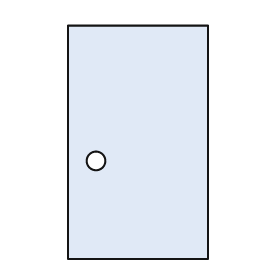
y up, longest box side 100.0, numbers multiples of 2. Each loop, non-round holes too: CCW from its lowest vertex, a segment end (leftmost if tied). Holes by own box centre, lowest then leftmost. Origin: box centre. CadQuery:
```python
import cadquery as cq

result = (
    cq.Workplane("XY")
    .moveTo(-30.0, -50.0)
    .lineTo(30.0, -50.0)
    .lineTo(30.0, 50.0)
    .lineTo(-30.0, 50.0)
    .close()
    .moveTo(-18.0, -8.0)
    .circle(4.0)
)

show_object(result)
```